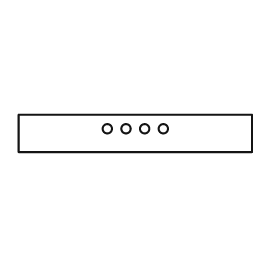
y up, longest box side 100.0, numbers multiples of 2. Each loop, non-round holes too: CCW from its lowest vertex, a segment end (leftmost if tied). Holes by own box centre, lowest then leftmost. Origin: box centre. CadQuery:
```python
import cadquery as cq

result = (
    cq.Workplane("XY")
    .moveTo(-50.0, -8.0)
    .lineTo(50.0, -8.0)
    .lineTo(50.0, 8.0)
    .lineTo(-50.0, 8.0)
    .close()
    .moveTo(-12.0, 2.0)
    .circle(2.0)
    .moveTo(-4.0, 2.0)
    .circle(2.0)
    .moveTo(4.0, 2.0)
    .circle(2.0)
    .moveTo(12.0, 2.0)
    .circle(2.0)
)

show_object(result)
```